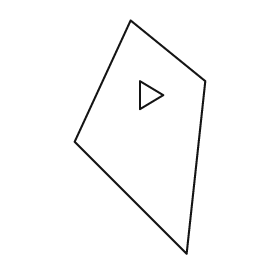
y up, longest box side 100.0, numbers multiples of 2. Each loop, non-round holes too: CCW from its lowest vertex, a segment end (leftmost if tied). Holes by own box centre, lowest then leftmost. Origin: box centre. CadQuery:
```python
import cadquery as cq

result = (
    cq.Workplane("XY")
    .moveTo(20.0, -50.0)
    .lineTo(28.0, 24.0)
    .lineTo(-4.0, 50.0)
    .lineTo(-28.0, -2.0)
    .close()
    .moveTo(0.0, 12.0)
    .lineTo(10.0, 18.0)
    .lineTo(0.0, 24.0)
    .close()
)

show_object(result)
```